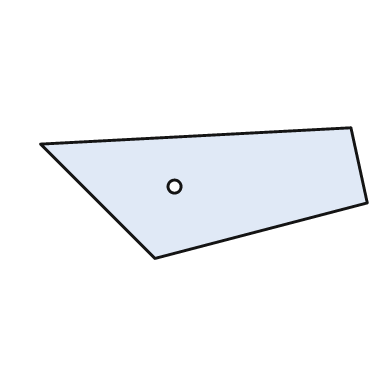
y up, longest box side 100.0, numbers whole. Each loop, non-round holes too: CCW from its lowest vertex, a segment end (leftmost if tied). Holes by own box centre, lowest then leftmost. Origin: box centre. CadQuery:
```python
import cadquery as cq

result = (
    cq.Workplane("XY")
    .moveTo(-15.0, -20.0)
    .lineTo(50.0, -3.0)
    .lineTo(45.0, 20.0)
    .lineTo(-50.0, 15.0)
    .close()
    .moveTo(-9.0, 2.0)
    .circle(2.0)
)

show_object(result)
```